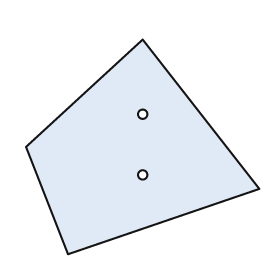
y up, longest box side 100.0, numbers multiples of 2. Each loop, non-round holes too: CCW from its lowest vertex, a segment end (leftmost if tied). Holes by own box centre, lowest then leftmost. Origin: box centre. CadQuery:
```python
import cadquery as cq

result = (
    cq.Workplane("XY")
    .moveTo(-32.0, -46.0)
    .lineTo(50.0, -18.0)
    .lineTo(0.0, 46.0)
    .lineTo(-50.0, 0.0)
    .close()
    .moveTo(0.0, -12.0)
    .circle(2.0)
    .moveTo(0.0, 14.0)
    .circle(2.0)
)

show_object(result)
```